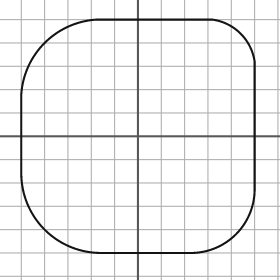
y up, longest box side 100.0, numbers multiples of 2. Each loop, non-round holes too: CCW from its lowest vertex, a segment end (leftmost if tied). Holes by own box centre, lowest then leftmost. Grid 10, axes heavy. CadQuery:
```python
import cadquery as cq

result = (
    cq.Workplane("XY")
    .moveTo(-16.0, -50.0)
    .lineTo(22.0, -50.0)
    .threePointArc((42.0, -42.0), (50.0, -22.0))
    .lineTo(50.0, 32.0)
    .threePointArc((44.0, 44.0), (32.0, 50.0))
    .lineTo(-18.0, 50.0)
    .threePointArc((-40.0, 40.0), (-50.0, 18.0))
    .lineTo(-50.0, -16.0)
    .threePointArc((-40.0, -40.0), (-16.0, -50.0))
    .close()
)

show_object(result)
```